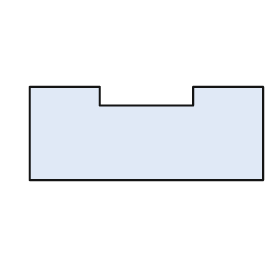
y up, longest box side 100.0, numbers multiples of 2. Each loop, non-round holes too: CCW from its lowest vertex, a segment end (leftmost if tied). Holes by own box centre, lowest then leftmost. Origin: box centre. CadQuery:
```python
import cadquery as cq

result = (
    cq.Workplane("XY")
    .moveTo(-50.0, -20.0)
    .lineTo(50.0, -20.0)
    .lineTo(50.0, 20.0)
    .lineTo(20.0, 20.0)
    .lineTo(20.0, 12.0)
    .lineTo(-20.0, 12.0)
    .lineTo(-20.0, 20.0)
    .lineTo(-50.0, 20.0)
    .close()
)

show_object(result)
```